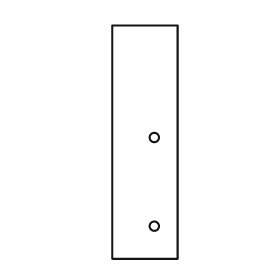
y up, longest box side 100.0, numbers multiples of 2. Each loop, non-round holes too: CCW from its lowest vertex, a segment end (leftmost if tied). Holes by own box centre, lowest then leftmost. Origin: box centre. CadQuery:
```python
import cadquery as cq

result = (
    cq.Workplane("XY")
    .moveTo(-14.0, -50.0)
    .lineTo(14.0, -50.0)
    .lineTo(14.0, 50.0)
    .lineTo(-14.0, 50.0)
    .close()
    .moveTo(4.0, -36.0)
    .circle(2.0)
    .moveTo(4.0, 2.0)
    .circle(2.0)
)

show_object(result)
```